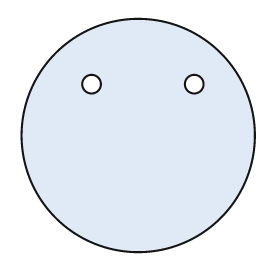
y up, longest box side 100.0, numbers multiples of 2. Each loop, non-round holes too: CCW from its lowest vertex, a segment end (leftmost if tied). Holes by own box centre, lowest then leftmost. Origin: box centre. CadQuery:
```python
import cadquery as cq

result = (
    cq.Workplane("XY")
    .moveTo(0.0, 0.0)
    .circle(50.0)
    .moveTo(-20.0, 22.0)
    .circle(4.0)
    .moveTo(24.0, 22.0)
    .circle(4.0)
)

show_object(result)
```